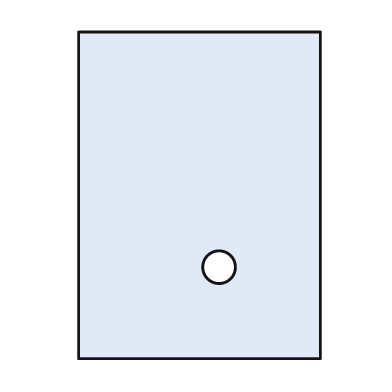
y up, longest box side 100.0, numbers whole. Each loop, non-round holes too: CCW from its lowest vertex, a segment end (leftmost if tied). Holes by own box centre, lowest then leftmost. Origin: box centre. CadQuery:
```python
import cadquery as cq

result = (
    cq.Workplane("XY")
    .moveTo(-37.0, -50.0)
    .lineTo(37.0, -50.0)
    .lineTo(37.0, 50.0)
    .lineTo(-37.0, 50.0)
    .close()
    .moveTo(6.0, -22.0)
    .circle(5.0)
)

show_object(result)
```